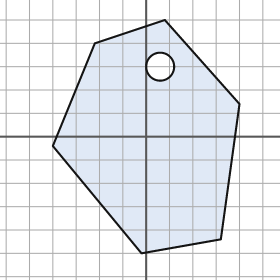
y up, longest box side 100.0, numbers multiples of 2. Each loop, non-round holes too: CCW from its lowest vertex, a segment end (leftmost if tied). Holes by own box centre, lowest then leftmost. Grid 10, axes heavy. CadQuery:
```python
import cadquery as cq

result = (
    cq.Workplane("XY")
    .moveTo(-2.0, -50.0)
    .lineTo(32.0, -44.0)
    .lineTo(40.0, 14.0)
    .lineTo(8.0, 50.0)
    .lineTo(-22.0, 40.0)
    .lineTo(-40.0, -4.0)
    .close()
    .moveTo(6.0, 30.0)
    .circle(6.0)
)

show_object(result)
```